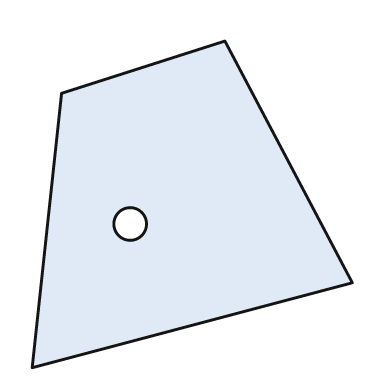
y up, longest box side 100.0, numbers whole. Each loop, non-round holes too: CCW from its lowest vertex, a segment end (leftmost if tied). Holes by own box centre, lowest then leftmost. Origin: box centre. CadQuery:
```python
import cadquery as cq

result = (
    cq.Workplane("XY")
    .moveTo(-49.0, -50.0)
    .lineTo(49.0, -24.0)
    .lineTo(10.0, 50.0)
    .lineTo(-40.0, 34.0)
    .close()
    .moveTo(-19.0, -6.0)
    .circle(5.0)
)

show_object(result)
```